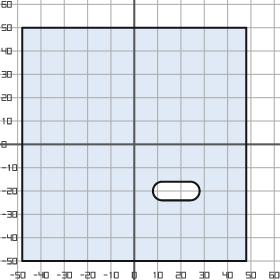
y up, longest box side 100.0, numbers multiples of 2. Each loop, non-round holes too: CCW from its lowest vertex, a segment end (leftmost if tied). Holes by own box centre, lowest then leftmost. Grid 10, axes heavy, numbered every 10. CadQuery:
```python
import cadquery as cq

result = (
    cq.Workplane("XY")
    .moveTo(-48.0, -50.0)
    .lineTo(48.0, -50.0)
    .lineTo(48.0, 50.0)
    .lineTo(-48.0, 50.0)
    .close()
    .moveTo(12.0, -24.0)
    .lineTo(24.0, -24.0)
    .threePointArc((28.0, -20.0), (24.0, -16.0))
    .lineTo(12.0, -16.0)
    .threePointArc((8.0, -20.0), (12.0, -24.0))
    .close()
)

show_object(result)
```